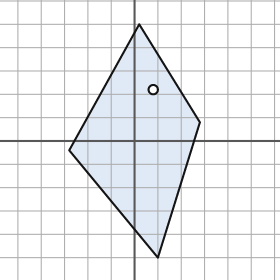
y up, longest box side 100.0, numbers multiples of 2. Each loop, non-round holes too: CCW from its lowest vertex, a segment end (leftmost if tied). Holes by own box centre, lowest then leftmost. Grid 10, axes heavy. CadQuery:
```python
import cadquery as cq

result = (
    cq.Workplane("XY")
    .moveTo(10.0, -50.0)
    .lineTo(28.0, 8.0)
    .lineTo(2.0, 50.0)
    .lineTo(-28.0, -4.0)
    .close()
    .moveTo(8.0, 22.0)
    .circle(2.0)
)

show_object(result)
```